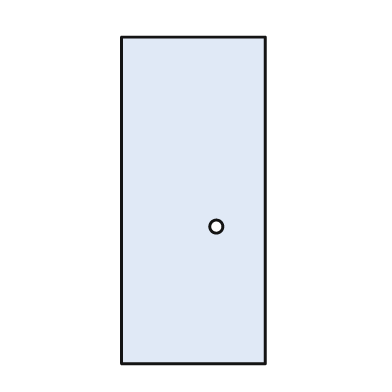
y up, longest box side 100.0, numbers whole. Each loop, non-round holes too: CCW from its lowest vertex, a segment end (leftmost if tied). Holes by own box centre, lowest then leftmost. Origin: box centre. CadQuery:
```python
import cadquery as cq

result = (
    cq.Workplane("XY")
    .moveTo(-22.0, -50.0)
    .lineTo(22.0, -50.0)
    .lineTo(22.0, 50.0)
    .lineTo(-22.0, 50.0)
    .close()
    .moveTo(7.0, -8.0)
    .circle(2.0)
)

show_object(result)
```